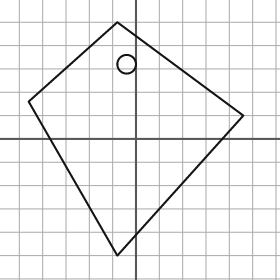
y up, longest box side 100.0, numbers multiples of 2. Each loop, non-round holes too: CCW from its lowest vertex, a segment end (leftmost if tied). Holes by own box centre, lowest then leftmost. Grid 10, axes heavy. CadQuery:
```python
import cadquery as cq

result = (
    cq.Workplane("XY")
    .moveTo(-8.0, -50.0)
    .lineTo(46.0, 10.0)
    .lineTo(-8.0, 50.0)
    .lineTo(-46.0, 16.0)
    .close()
    .moveTo(-4.0, 32.0)
    .circle(4.0)
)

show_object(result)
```